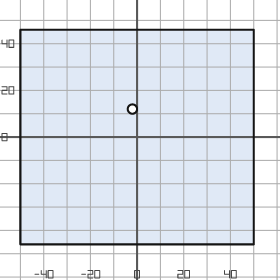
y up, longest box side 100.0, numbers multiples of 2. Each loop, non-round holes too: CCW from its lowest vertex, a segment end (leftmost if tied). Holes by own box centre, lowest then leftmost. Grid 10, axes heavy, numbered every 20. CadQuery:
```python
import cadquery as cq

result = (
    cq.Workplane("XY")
    .moveTo(-50.0, -46.0)
    .lineTo(50.0, -46.0)
    .lineTo(50.0, 46.0)
    .lineTo(-50.0, 46.0)
    .close()
    .moveTo(-2.0, 12.0)
    .circle(2.0)
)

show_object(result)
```